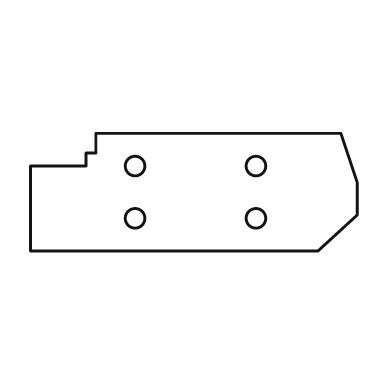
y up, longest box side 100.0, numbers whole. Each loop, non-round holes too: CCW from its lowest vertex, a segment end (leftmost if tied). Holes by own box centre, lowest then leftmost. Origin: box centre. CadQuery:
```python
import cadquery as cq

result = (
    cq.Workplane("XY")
    .moveTo(-50.0, -18.0)
    .lineTo(38.0, -18.0)
    .lineTo(50.0, -7.0)
    .lineTo(50.0, 3.0)
    .lineTo(45.0, 18.0)
    .lineTo(-30.0, 18.0)
    .lineTo(-30.0, 12.0)
    .lineTo(-33.0, 12.0)
    .lineTo(-33.0, 8.0)
    .lineTo(-50.0, 8.0)
    .close()
    .moveTo(-18.0, -8.0)
    .circle(3.0)
    .moveTo(19.0, -8.0)
    .circle(3.0)
    .moveTo(-18.0, 8.0)
    .circle(3.0)
    .moveTo(19.0, 8.0)
    .circle(3.0)
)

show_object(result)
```